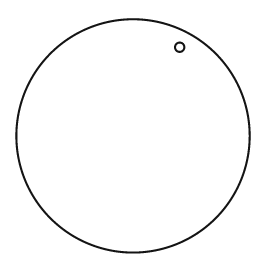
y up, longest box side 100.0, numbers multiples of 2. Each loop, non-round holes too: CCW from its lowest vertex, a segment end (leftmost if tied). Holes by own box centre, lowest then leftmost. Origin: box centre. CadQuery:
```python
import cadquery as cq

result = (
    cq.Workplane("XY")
    .moveTo(0.0, 0.0)
    .circle(50.0)
    .moveTo(20.0, 38.0)
    .circle(2.0)
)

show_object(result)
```